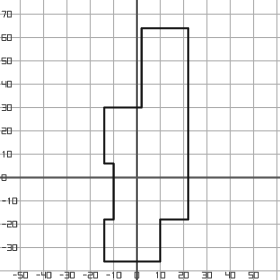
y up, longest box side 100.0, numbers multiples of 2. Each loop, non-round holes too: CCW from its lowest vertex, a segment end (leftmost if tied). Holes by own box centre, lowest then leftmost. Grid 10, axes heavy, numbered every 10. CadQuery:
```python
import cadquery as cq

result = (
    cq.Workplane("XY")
    .moveTo(-14.0, -36.0)
    .lineTo(10.0, -36.0)
    .lineTo(10.0, -18.0)
    .lineTo(22.0, -18.0)
    .lineTo(22.0, 64.0)
    .lineTo(2.0, 64.0)
    .lineTo(2.0, 30.0)
    .lineTo(-14.0, 30.0)
    .lineTo(-14.0, 6.0)
    .lineTo(-10.0, 6.0)
    .lineTo(-10.0, -18.0)
    .lineTo(-14.0, -18.0)
    .close()
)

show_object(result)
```